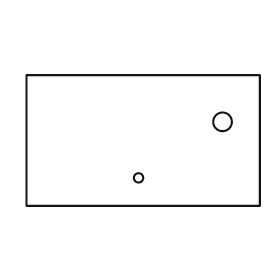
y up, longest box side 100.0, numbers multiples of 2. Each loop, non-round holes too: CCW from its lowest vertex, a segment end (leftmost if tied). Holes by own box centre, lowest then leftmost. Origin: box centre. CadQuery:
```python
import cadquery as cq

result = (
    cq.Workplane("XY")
    .moveTo(-50.0, -28.0)
    .lineTo(50.0, -28.0)
    .lineTo(50.0, 28.0)
    .lineTo(-50.0, 28.0)
    .close()
    .moveTo(-2.0, -16.0)
    .circle(2.0)
    .moveTo(34.0, 8.0)
    .circle(4.0)
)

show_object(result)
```